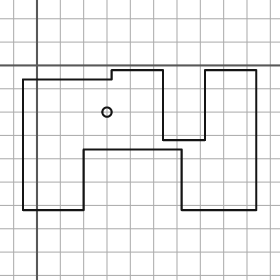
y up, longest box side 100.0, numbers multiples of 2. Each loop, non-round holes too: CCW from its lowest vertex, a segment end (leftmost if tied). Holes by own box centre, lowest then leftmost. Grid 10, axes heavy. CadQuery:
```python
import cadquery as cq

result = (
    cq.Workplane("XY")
    .moveTo(-6.0, -62.0)
    .lineTo(20.0, -62.0)
    .lineTo(20.0, -36.0)
    .lineTo(62.0, -36.0)
    .lineTo(62.0, -62.0)
    .lineTo(94.0, -62.0)
    .lineTo(94.0, -2.0)
    .lineTo(72.0, -2.0)
    .lineTo(72.0, -32.0)
    .lineTo(54.0, -32.0)
    .lineTo(54.0, -2.0)
    .lineTo(32.0, -2.0)
    .lineTo(32.0, -6.0)
    .lineTo(-6.0, -6.0)
    .close()
    .moveTo(30.0, -20.0)
    .circle(2.0)
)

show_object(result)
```